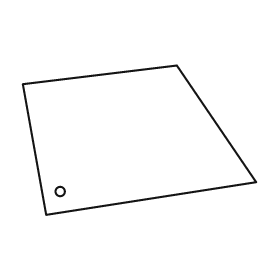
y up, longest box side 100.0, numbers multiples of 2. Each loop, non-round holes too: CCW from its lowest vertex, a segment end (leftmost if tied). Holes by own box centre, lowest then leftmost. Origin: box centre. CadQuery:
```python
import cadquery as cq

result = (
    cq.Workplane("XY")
    .moveTo(-40.0, -32.0)
    .lineTo(50.0, -18.0)
    .lineTo(16.0, 32.0)
    .lineTo(-50.0, 24.0)
    .close()
    .moveTo(-34.0, -22.0)
    .circle(2.0)
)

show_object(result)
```